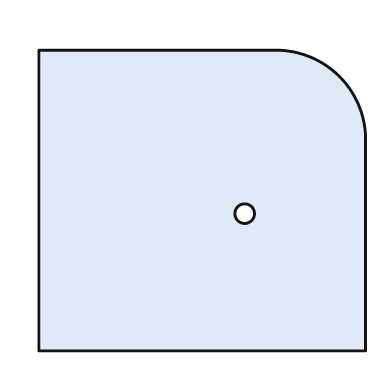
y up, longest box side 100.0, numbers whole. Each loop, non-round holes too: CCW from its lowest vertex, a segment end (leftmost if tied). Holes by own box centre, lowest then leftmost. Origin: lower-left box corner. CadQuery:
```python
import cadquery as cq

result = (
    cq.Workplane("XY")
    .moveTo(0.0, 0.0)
    .lineTo(100.0, 0.0)
    .lineTo(100.0, 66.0)
    .threePointArc((92.0, 84.0), (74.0, 92.0))
    .lineTo(0.0, 92.0)
    .close()
    .moveTo(63.0, 42.0)
    .circle(3.0)
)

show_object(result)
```